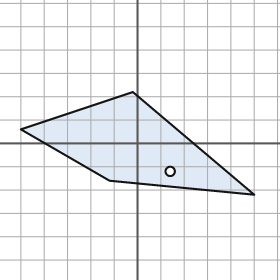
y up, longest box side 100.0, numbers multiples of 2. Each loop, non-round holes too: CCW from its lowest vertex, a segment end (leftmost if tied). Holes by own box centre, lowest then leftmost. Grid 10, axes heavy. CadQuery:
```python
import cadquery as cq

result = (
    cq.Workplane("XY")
    .moveTo(50.0, -22.0)
    .lineTo(-2.0, 22.0)
    .lineTo(-50.0, 6.0)
    .lineTo(-12.0, -16.0)
    .close()
    .moveTo(14.0, -12.0)
    .circle(2.0)
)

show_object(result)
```